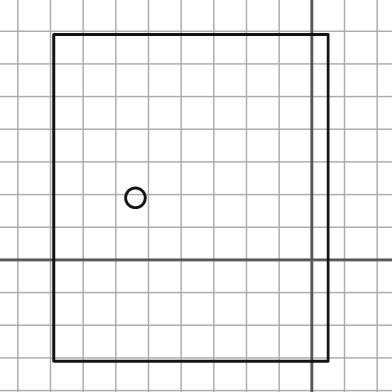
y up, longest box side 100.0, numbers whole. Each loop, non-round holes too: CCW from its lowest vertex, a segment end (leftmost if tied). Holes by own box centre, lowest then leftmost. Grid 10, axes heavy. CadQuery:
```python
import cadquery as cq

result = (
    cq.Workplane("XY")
    .moveTo(-79.0, -31.0)
    .lineTo(5.0, -31.0)
    .lineTo(5.0, 69.0)
    .lineTo(-79.0, 69.0)
    .close()
    .moveTo(-54.0, 19.0)
    .circle(3.0)
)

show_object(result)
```